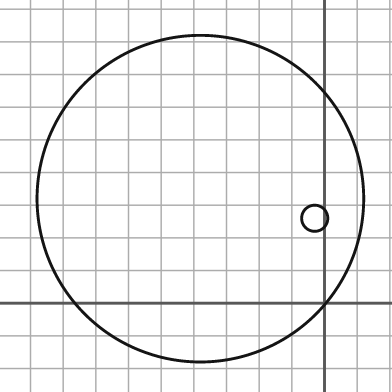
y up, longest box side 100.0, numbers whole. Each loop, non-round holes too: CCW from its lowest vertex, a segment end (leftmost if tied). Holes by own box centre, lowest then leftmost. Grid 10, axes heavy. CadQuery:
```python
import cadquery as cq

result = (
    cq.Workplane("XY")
    .moveTo(-38.0, 32.0)
    .circle(50.0)
    .moveTo(-3.0, 26.0)
    .circle(4.0)
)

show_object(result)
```